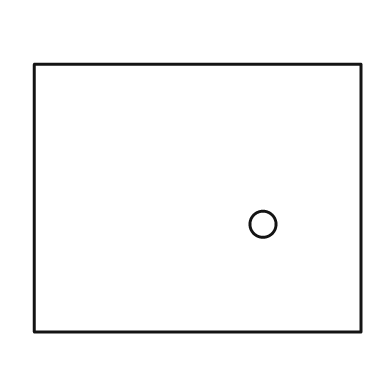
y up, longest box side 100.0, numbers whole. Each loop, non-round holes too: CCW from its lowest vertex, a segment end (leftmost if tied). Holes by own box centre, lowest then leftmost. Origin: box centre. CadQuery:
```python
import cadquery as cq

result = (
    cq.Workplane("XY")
    .moveTo(-50.0, -41.0)
    .lineTo(50.0, -41.0)
    .lineTo(50.0, 41.0)
    .lineTo(-50.0, 41.0)
    .close()
    .moveTo(20.0, -8.0)
    .circle(4.0)
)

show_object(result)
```